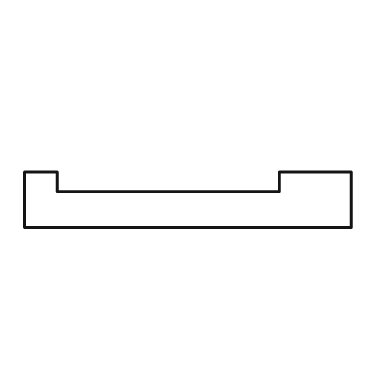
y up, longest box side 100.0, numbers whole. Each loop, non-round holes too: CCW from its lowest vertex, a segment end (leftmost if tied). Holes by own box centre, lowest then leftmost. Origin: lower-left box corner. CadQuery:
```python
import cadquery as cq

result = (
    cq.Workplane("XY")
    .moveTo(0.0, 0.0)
    .lineTo(100.0, 0.0)
    .lineTo(100.0, 17.0)
    .lineTo(78.0, 17.0)
    .lineTo(78.0, 11.0)
    .lineTo(10.0, 11.0)
    .lineTo(10.0, 17.0)
    .lineTo(0.0, 17.0)
    .close()
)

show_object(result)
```